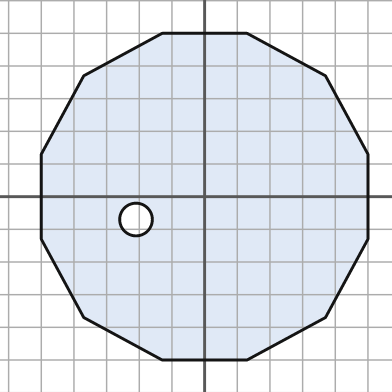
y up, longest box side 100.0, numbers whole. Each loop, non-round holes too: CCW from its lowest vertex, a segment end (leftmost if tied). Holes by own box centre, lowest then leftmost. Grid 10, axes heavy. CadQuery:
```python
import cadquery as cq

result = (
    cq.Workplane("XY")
    .moveTo(-13.0, -50.0)
    .lineTo(13.0, -50.0)
    .lineTo(37.0, -37.0)
    .lineTo(50.0, -13.0)
    .lineTo(50.0, 13.0)
    .lineTo(37.0, 37.0)
    .lineTo(13.0, 50.0)
    .lineTo(-13.0, 50.0)
    .lineTo(-37.0, 37.0)
    .lineTo(-50.0, 13.0)
    .lineTo(-50.0, -13.0)
    .lineTo(-37.0, -37.0)
    .close()
    .moveTo(-21.0, -7.0)
    .circle(5.0)
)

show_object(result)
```